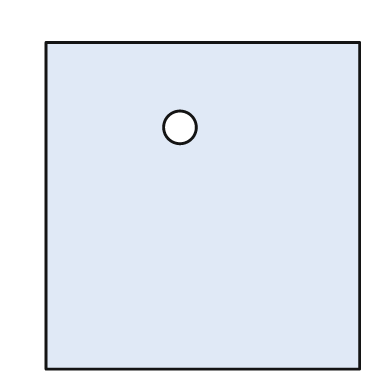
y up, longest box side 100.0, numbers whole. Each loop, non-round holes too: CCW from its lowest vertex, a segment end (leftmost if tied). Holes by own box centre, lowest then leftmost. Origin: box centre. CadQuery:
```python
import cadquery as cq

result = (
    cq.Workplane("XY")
    .moveTo(-48.0, -50.0)
    .lineTo(48.0, -50.0)
    .lineTo(48.0, 50.0)
    .lineTo(-48.0, 50.0)
    .close()
    .moveTo(-7.0, 24.0)
    .circle(5.0)
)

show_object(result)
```